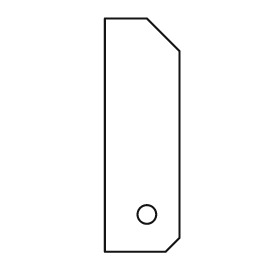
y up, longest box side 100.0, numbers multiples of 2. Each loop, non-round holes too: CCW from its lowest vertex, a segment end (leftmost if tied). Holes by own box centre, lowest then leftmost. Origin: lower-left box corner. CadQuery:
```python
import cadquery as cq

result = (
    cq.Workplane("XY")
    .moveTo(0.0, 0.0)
    .lineTo(26.0, 0.0)
    .lineTo(32.0, 6.0)
    .lineTo(32.0, 86.0)
    .lineTo(18.0, 100.0)
    .lineTo(0.0, 100.0)
    .close()
    .moveTo(18.0, 16.0)
    .circle(4.0)
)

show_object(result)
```